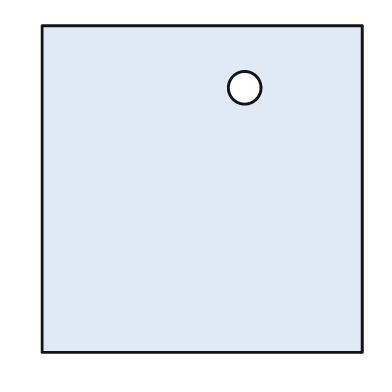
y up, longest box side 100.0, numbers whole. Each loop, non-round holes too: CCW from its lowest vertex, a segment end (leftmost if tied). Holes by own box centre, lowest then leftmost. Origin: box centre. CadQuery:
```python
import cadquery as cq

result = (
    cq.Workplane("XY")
    .moveTo(-49.0, -50.0)
    .lineTo(49.0, -50.0)
    .lineTo(49.0, 50.0)
    .lineTo(-49.0, 50.0)
    .close()
    .moveTo(13.0, 31.0)
    .circle(5.0)
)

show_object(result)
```